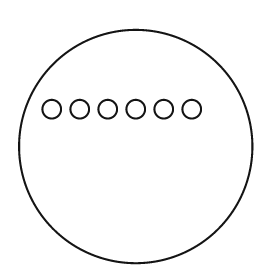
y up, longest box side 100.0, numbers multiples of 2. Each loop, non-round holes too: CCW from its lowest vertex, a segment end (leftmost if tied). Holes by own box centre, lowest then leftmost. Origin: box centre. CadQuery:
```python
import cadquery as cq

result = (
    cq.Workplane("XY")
    .moveTo(0.0, 0.0)
    .circle(50.0)
    .moveTo(-36.0, 16.0)
    .circle(4.0)
    .moveTo(-24.0, 16.0)
    .circle(4.0)
    .moveTo(-12.0, 16.0)
    .circle(4.0)
    .moveTo(0.0, 16.0)
    .circle(4.0)
    .moveTo(12.0, 16.0)
    .circle(4.0)
    .moveTo(24.0, 16.0)
    .circle(4.0)
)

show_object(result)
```